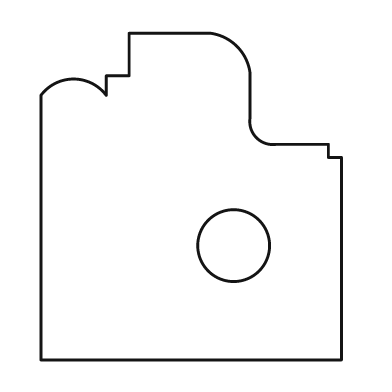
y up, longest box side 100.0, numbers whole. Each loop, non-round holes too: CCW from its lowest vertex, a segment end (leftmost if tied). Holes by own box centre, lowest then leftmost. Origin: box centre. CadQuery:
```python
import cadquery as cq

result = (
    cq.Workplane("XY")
    .moveTo(-46.0, -50.0)
    .lineTo(46.0, -50.0)
    .lineTo(46.0, 12.0)
    .lineTo(42.0, 12.0)
    .lineTo(42.0, 16.0)
    .lineTo(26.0, 16.0)
    .threePointArc((20.0, 18.0), (18.0, 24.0))
    .lineTo(18.0, 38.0)
    .threePointArc((14.0, 46.0), (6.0, 50.0))
    .lineTo(-19.0, 50.0)
    .lineTo(-19.0, 37.0)
    .lineTo(-26.0, 37.0)
    .lineTo(-26.0, 31.0)
    .threePointArc((-36.0, 36.0), (-46.0, 31.0))
    .close()
    .moveTo(13.0, -15.0)
    .circle(11.0)
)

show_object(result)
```